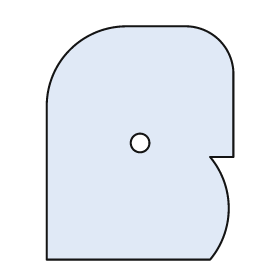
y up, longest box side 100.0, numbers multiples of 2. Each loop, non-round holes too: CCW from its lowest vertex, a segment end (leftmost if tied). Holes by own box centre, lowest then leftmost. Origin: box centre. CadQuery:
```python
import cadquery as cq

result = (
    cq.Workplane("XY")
    .moveTo(-40.0, -50.0)
    .lineTo(30.0, -50.0)
    .threePointArc((38.0, -28.0), (30.0, -6.0))
    .lineTo(40.0, -6.0)
    .lineTo(40.0, 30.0)
    .threePointArc((34.0, 44.0), (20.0, 50.0))
    .lineTo(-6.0, 50.0)
    .threePointArc((-30.0, 40.0), (-40.0, 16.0))
    .close()
    .moveTo(0.0, 0.0)
    .circle(4.0)
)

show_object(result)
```